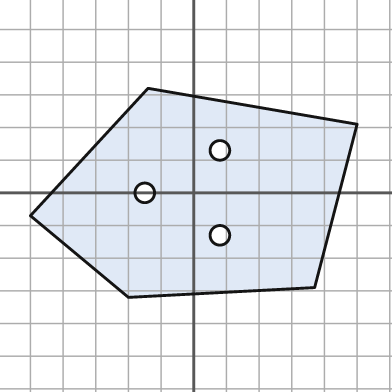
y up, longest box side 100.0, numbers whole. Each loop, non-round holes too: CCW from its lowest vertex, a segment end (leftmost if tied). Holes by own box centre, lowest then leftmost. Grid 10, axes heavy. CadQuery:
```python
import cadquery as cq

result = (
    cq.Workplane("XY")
    .moveTo(-20.0, -32.0)
    .lineTo(37.0, -29.0)
    .lineTo(50.0, 21.0)
    .lineTo(-14.0, 32.0)
    .lineTo(-50.0, -7.0)
    .close()
    .moveTo(8.0, -13.0)
    .circle(3.0)
    .moveTo(-15.0, 0.0)
    .circle(3.0)
    .moveTo(8.0, 13.0)
    .circle(3.0)
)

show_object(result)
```